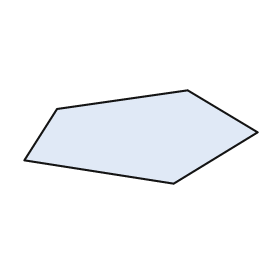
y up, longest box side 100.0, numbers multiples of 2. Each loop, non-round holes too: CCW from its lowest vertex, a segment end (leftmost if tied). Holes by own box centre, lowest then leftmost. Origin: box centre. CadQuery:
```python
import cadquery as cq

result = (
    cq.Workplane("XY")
    .moveTo(14.0, -20.0)
    .lineTo(50.0, 2.0)
    .lineTo(20.0, 20.0)
    .lineTo(-36.0, 12.0)
    .lineTo(-50.0, -10.0)
    .close()
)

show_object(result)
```